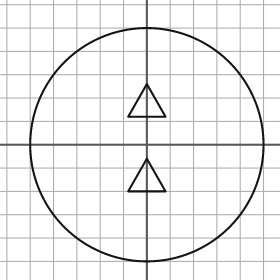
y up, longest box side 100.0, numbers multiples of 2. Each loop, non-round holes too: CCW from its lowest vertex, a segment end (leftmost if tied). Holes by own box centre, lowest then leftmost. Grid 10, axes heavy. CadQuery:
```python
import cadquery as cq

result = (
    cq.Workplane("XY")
    .moveTo(0.0, 0.0)
    .circle(50.0)
    .moveTo(-8.0, -20.0)
    .lineTo(8.0, -20.0)
    .lineTo(0.0, -6.0)
    .close()
    .moveTo(-8.0, 12.0)
    .lineTo(8.0, 12.0)
    .lineTo(0.0, 26.0)
    .close()
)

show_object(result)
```